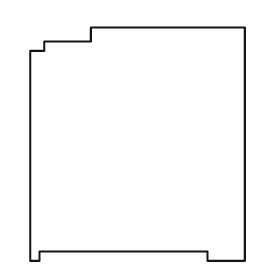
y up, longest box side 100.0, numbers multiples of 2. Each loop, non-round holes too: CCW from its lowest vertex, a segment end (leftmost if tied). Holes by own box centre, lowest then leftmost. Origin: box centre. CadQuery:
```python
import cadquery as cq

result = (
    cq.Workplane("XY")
    .moveTo(-46.0, -50.0)
    .lineTo(-42.0, -50.0)
    .lineTo(-42.0, -46.0)
    .lineTo(30.0, -46.0)
    .lineTo(30.0, -50.0)
    .lineTo(46.0, -50.0)
    .lineTo(46.0, 50.0)
    .lineTo(-20.0, 50.0)
    .lineTo(-20.0, 44.0)
    .lineTo(-40.0, 44.0)
    .lineTo(-40.0, 40.0)
    .lineTo(-46.0, 40.0)
    .close()
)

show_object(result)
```